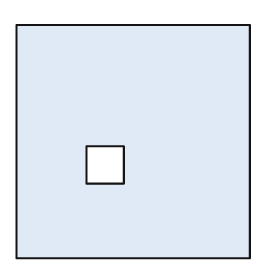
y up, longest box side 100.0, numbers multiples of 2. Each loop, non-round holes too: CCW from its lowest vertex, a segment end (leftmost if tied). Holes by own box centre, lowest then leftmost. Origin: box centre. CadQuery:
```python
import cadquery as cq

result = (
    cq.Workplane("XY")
    .moveTo(-50.0, -50.0)
    .lineTo(50.0, -50.0)
    .lineTo(50.0, 50.0)
    .lineTo(-50.0, 50.0)
    .close()
    .moveTo(-20.0, -18.0)
    .lineTo(-4.0, -18.0)
    .lineTo(-4.0, -2.0)
    .lineTo(-20.0, -2.0)
    .close()
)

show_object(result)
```